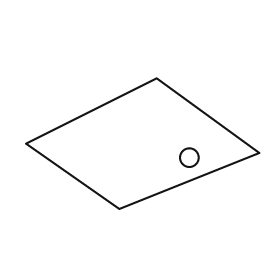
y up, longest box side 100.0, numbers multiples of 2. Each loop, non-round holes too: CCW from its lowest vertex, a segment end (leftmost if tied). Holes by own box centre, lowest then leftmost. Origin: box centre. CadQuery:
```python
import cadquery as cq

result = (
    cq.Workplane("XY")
    .moveTo(-10.0, -28.0)
    .lineTo(50.0, -4.0)
    .lineTo(6.0, 28.0)
    .lineTo(-50.0, 0.0)
    .close()
    .moveTo(20.0, -6.0)
    .circle(4.0)
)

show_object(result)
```